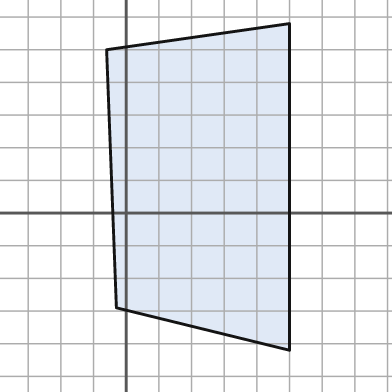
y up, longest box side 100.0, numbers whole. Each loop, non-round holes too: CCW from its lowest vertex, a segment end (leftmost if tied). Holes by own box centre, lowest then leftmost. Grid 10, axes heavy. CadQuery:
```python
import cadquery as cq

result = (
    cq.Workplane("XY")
    .moveTo(50.0, -42.0)
    .lineTo(50.0, 58.0)
    .lineTo(-6.0, 50.0)
    .lineTo(-3.0, -29.0)
    .close()
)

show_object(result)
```